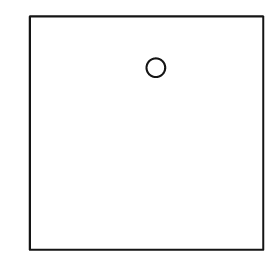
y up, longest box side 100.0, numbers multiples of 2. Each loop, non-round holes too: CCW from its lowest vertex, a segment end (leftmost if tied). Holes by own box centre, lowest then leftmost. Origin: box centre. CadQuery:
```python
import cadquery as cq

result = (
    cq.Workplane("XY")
    .moveTo(-50.0, -50.0)
    .lineTo(50.0, -50.0)
    .lineTo(50.0, 50.0)
    .lineTo(-50.0, 50.0)
    .close()
    .moveTo(4.0, 28.0)
    .circle(4.0)
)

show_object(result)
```